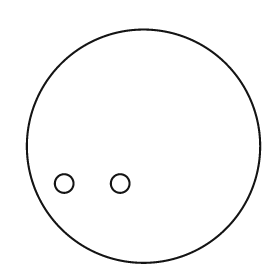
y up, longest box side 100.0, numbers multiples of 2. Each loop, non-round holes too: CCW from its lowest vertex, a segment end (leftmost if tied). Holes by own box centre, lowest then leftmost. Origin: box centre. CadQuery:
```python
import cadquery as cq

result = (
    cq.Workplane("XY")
    .moveTo(0.0, 0.0)
    .circle(50.0)
    .moveTo(-34.0, -16.0)
    .circle(4.0)
    .moveTo(-10.0, -16.0)
    .circle(4.0)
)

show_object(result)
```